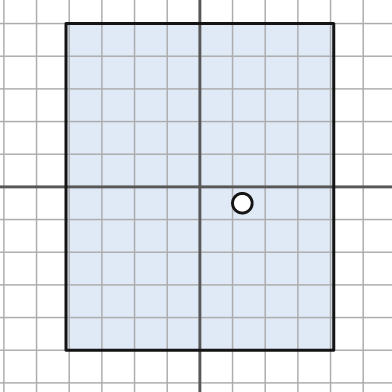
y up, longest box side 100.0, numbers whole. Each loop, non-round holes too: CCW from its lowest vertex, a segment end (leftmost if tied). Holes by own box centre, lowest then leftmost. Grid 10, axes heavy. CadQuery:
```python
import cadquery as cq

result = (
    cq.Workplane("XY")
    .moveTo(-41.0, -50.0)
    .lineTo(41.0, -50.0)
    .lineTo(41.0, 50.0)
    .lineTo(-41.0, 50.0)
    .close()
    .moveTo(13.0, -5.0)
    .circle(3.0)
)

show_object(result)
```